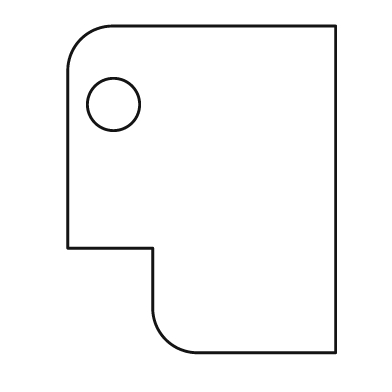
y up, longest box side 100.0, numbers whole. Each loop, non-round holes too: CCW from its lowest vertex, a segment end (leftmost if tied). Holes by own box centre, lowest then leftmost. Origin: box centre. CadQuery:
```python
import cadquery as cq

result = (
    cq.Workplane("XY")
    .moveTo(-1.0, -50.0)
    .lineTo(41.0, -50.0)
    .lineTo(41.0, 50.0)
    .lineTo(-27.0, 50.0)
    .threePointArc((-37.0, 46.0), (-41.0, 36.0))
    .lineTo(-41.0, -18.0)
    .lineTo(-15.0, -18.0)
    .lineTo(-15.0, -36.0)
    .threePointArc((-11.0, -46.0), (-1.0, -50.0))
    .close()
    .moveTo(-27.0, 26.0)
    .circle(8.0)
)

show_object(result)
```